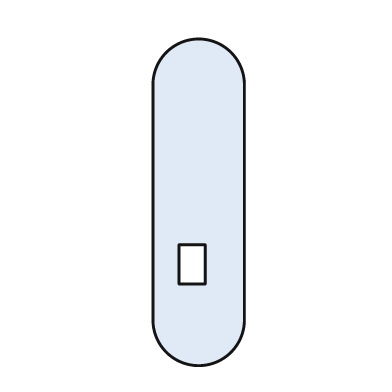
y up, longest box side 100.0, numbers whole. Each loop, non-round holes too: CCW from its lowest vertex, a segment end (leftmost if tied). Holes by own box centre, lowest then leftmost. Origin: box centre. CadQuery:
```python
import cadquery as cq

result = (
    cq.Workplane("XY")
    .moveTo(-14.0, -36.0)
    .threePointArc((0.0, -50.0), (14.0, -36.0))
    .lineTo(14.0, 36.0)
    .threePointArc((0.0, 50.0), (-14.0, 36.0))
    .close()
    .moveTo(-6.0, -25.0)
    .lineTo(2.0, -25.0)
    .lineTo(2.0, -13.0)
    .lineTo(-6.0, -13.0)
    .close()
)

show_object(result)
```